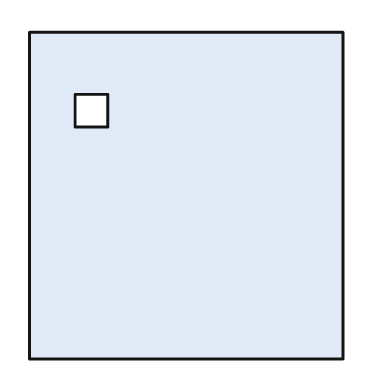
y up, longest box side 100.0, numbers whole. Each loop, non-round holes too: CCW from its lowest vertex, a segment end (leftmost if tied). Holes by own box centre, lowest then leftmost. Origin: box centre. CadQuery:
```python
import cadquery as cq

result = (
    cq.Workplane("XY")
    .moveTo(-48.0, -50.0)
    .lineTo(48.0, -50.0)
    .lineTo(48.0, 50.0)
    .lineTo(-48.0, 50.0)
    .close()
    .moveTo(-34.0, 21.0)
    .lineTo(-24.0, 21.0)
    .lineTo(-24.0, 31.0)
    .lineTo(-34.0, 31.0)
    .close()
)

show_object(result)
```